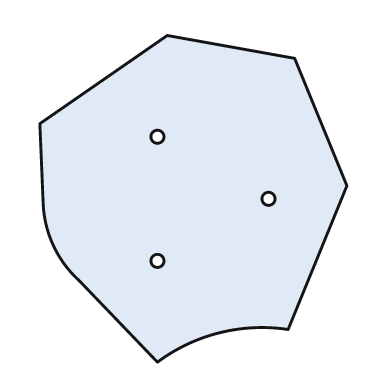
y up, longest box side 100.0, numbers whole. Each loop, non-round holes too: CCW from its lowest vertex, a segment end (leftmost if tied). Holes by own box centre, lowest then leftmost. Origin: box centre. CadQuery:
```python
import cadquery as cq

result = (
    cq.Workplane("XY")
    .moveTo(-11.0, -50.0)
    .threePointArc((8.0, -41.0), (29.0, -40.0))
    .lineTo(47.0, 4.0)
    .lineTo(31.0, 43.0)
    .lineTo(-8.0, 50.0)
    .lineTo(-47.0, 23.0)
    .lineTo(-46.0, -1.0)
    .threePointArc((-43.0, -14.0), (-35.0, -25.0))
    .close()
    .moveTo(-11.0, -19.0)
    .circle(2.0)
    .moveTo(23.0, 0.0)
    .circle(2.0)
    .moveTo(-11.0, 19.0)
    .circle(2.0)
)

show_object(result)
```